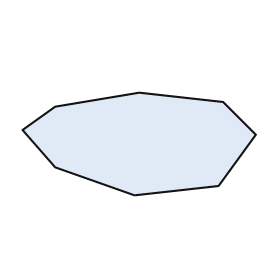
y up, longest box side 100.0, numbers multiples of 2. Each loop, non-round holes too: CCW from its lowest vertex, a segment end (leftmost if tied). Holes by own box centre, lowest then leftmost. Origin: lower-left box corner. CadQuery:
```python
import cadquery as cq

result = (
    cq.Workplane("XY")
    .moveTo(48.0, 0.0)
    .lineTo(84.0, 4.0)
    .lineTo(100.0, 26.0)
    .lineTo(86.0, 40.0)
    .lineTo(50.0, 44.0)
    .lineTo(14.0, 38.0)
    .lineTo(0.0, 28.0)
    .lineTo(14.0, 12.0)
    .close()
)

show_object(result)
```